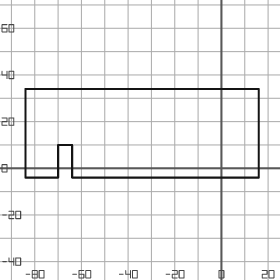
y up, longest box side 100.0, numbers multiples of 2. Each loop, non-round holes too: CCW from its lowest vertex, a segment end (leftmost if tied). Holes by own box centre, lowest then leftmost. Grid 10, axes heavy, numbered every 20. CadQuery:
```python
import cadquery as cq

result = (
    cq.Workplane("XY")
    .moveTo(-84.0, -4.0)
    .lineTo(-70.0, -4.0)
    .lineTo(-70.0, 10.0)
    .lineTo(-64.0, 10.0)
    .lineTo(-64.0, -4.0)
    .lineTo(16.0, -4.0)
    .lineTo(16.0, 34.0)
    .lineTo(-84.0, 34.0)
    .close()
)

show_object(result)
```